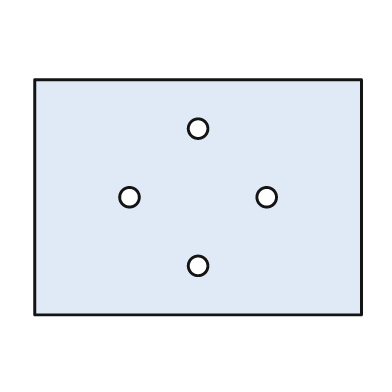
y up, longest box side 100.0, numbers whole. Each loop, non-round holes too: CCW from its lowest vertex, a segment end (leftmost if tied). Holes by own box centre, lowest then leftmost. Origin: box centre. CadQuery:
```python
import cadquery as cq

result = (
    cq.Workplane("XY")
    .moveTo(-50.0, -36.0)
    .lineTo(50.0, -36.0)
    .lineTo(50.0, 36.0)
    .lineTo(-50.0, 36.0)
    .close()
    .moveTo(0.0, -21.0)
    .circle(3.0)
    .moveTo(-21.0, 0.0)
    .circle(3.0)
    .moveTo(21.0, 0.0)
    .circle(3.0)
    .moveTo(0.0, 21.0)
    .circle(3.0)
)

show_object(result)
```